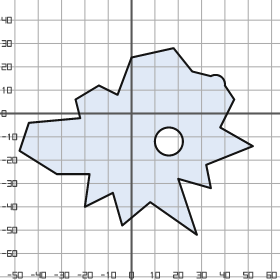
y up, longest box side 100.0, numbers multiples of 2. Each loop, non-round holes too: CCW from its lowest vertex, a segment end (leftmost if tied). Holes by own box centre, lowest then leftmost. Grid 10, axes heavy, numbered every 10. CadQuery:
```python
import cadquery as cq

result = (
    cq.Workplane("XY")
    .moveTo(28.0, -52.0)
    .lineTo(20.0, -28.0)
    .lineTo(34.0, -32.0)
    .lineTo(32.0, -22.0)
    .lineTo(52.0, -14.0)
    .lineTo(38.0, -6.0)
    .lineTo(44.0, 6.0)
    .lineTo(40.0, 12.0)
    .threePointArc((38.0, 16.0), (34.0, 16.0))
    .lineTo(26.0, 18.0)
    .lineTo(18.0, 28.0)
    .lineTo(0.0, 24.0)
    .lineTo(-6.0, 8.0)
    .lineTo(-14.0, 12.0)
    .lineTo(-24.0, 6.0)
    .lineTo(-22.0, -2.0)
    .lineTo(-44.0, -4.0)
    .lineTo(-48.0, -16.0)
    .lineTo(-32.0, -26.0)
    .lineTo(-18.0, -26.0)
    .lineTo(-20.0, -40.0)
    .lineTo(-8.0, -34.0)
    .lineTo(-4.0, -48.0)
    .lineTo(8.0, -38.0)
    .close()
    .moveTo(16.0, -12.0)
    .circle(6.0)
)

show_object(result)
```